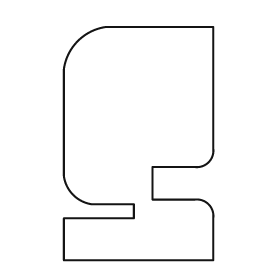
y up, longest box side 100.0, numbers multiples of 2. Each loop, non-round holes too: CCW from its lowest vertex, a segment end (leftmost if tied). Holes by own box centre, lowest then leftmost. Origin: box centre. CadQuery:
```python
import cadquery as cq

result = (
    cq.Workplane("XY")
    .moveTo(-32.0, -50.0)
    .lineTo(32.0, -50.0)
    .lineTo(32.0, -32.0)
    .threePointArc((30.0, -26.0), (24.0, -24.0))
    .lineTo(6.0, -24.0)
    .lineTo(6.0, -10.0)
    .lineTo(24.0, -10.0)
    .threePointArc((30.0, -8.0), (32.0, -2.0))
    .lineTo(32.0, 50.0)
    .lineTo(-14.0, 50.0)
    .threePointArc((-26.0, 44.0), (-32.0, 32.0))
    .lineTo(-32.0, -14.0)
    .threePointArc((-28.0, -22.0), (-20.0, -26.0))
    .lineTo(-2.0, -26.0)
    .lineTo(-2.0, -32.0)
    .lineTo(-32.0, -32.0)
    .close()
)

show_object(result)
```